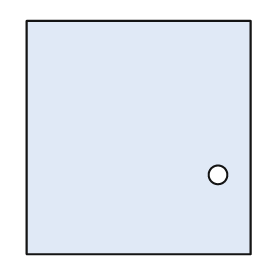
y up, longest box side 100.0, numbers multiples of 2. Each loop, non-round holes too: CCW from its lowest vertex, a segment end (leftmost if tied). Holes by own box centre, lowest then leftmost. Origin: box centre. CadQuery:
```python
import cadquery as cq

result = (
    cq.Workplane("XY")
    .moveTo(-48.0, -50.0)
    .lineTo(48.0, -50.0)
    .lineTo(48.0, 50.0)
    .lineTo(-48.0, 50.0)
    .close()
    .moveTo(34.0, -16.0)
    .circle(4.0)
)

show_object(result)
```